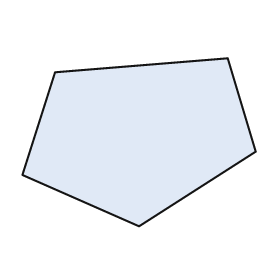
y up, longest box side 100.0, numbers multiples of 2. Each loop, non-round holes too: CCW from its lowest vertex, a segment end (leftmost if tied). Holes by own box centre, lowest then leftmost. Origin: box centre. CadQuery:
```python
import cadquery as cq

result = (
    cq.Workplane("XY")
    .moveTo(0.0, -36.0)
    .lineTo(50.0, -4.0)
    .lineTo(38.0, 36.0)
    .lineTo(-36.0, 30.0)
    .lineTo(-50.0, -14.0)
    .close()
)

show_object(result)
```